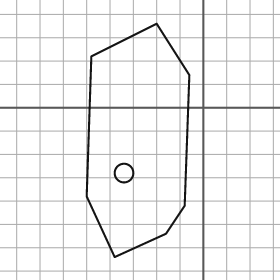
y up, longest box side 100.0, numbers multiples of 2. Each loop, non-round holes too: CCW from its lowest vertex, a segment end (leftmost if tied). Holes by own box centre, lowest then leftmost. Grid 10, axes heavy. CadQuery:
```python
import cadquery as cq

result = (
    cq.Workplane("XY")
    .moveTo(-38.0, -64.0)
    .lineTo(-16.0, -54.0)
    .lineTo(-8.0, -42.0)
    .lineTo(-6.0, 14.0)
    .lineTo(-20.0, 36.0)
    .lineTo(-48.0, 22.0)
    .lineTo(-50.0, -38.0)
    .close()
    .moveTo(-34.0, -28.0)
    .circle(4.0)
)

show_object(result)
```